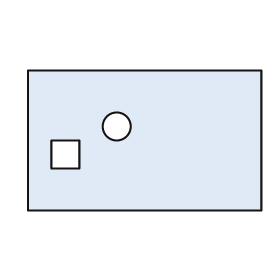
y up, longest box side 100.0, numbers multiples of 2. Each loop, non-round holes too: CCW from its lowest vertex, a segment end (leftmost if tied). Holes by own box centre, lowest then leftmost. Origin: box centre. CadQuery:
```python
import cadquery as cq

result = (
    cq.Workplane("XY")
    .moveTo(-50.0, -30.0)
    .lineTo(50.0, -30.0)
    .lineTo(50.0, 30.0)
    .lineTo(-50.0, 30.0)
    .close()
    .moveTo(-40.0, -12.0)
    .lineTo(-28.0, -12.0)
    .lineTo(-28.0, 0.0)
    .lineTo(-40.0, 0.0)
    .close()
    .moveTo(-12.0, 6.0)
    .circle(6.0)
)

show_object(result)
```